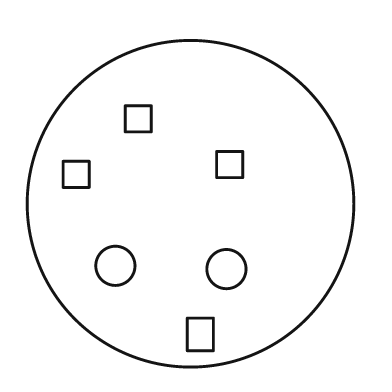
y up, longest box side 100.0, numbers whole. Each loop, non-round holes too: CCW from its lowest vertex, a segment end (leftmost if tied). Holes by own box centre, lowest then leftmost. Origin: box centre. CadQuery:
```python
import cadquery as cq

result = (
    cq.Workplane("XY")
    .moveTo(0.0, 0.0)
    .circle(50.0)
    .moveTo(-1.0, -45.0)
    .lineTo(7.0, -45.0)
    .lineTo(7.0, -35.0)
    .lineTo(-1.0, -35.0)
    .close()
    .moveTo(11.0, -20.0)
    .circle(6.0)
    .moveTo(-23.0, -19.0)
    .circle(6.0)
    .moveTo(-39.0, 5.0)
    .lineTo(-31.0, 5.0)
    .lineTo(-31.0, 13.0)
    .lineTo(-39.0, 13.0)
    .close()
    .moveTo(8.0, 8.0)
    .lineTo(16.0, 8.0)
    .lineTo(16.0, 16.0)
    .lineTo(8.0, 16.0)
    .close()
    .moveTo(-20.0, 22.0)
    .lineTo(-12.0, 22.0)
    .lineTo(-12.0, 30.0)
    .lineTo(-20.0, 30.0)
    .close()
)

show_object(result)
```